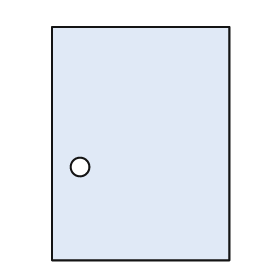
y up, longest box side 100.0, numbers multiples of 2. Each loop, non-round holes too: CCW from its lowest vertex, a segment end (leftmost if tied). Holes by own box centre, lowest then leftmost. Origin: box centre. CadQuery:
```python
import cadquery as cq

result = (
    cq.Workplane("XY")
    .moveTo(-38.0, -50.0)
    .lineTo(38.0, -50.0)
    .lineTo(38.0, 50.0)
    .lineTo(-38.0, 50.0)
    .close()
    .moveTo(-26.0, -10.0)
    .circle(4.0)
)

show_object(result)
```